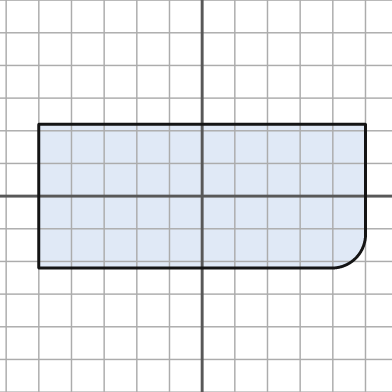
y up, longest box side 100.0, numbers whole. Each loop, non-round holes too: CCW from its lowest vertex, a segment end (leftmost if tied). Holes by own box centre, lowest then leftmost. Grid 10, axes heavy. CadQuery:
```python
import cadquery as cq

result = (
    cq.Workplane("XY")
    .moveTo(-50.0, -22.0)
    .lineTo(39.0, -22.0)
    .threePointArc((47.0, -19.0), (50.0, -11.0))
    .lineTo(50.0, 22.0)
    .lineTo(-50.0, 22.0)
    .close()
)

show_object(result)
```